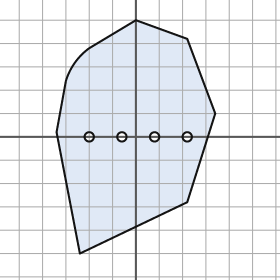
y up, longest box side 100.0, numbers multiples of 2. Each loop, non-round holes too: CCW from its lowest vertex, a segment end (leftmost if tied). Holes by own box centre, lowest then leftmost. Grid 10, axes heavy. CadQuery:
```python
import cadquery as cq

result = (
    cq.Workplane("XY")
    .moveTo(-24.0, -50.0)
    .lineTo(22.0, -28.0)
    .lineTo(34.0, 10.0)
    .lineTo(22.0, 42.0)
    .lineTo(0.0, 50.0)
    .lineTo(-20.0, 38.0)
    .threePointArc((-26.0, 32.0), (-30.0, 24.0))
    .lineTo(-34.0, 2.0)
    .close()
    .moveTo(-20.0, 0.0)
    .circle(2.0)
    .moveTo(-6.0, 0.0)
    .circle(2.0)
    .moveTo(8.0, 0.0)
    .circle(2.0)
    .moveTo(22.0, 0.0)
    .circle(2.0)
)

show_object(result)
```